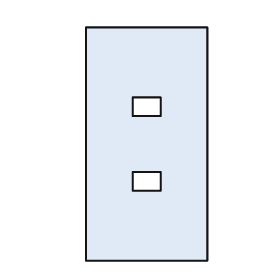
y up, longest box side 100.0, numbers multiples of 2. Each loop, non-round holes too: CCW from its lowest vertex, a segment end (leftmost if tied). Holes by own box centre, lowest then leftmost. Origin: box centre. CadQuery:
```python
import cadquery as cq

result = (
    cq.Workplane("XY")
    .moveTo(-26.0, -50.0)
    .lineTo(26.0, -50.0)
    .lineTo(26.0, 50.0)
    .lineTo(-26.0, 50.0)
    .close()
    .moveTo(-6.0, -20.0)
    .lineTo(6.0, -20.0)
    .lineTo(6.0, -12.0)
    .lineTo(-6.0, -12.0)
    .close()
    .moveTo(-6.0, 12.0)
    .lineTo(6.0, 12.0)
    .lineTo(6.0, 20.0)
    .lineTo(-6.0, 20.0)
    .close()
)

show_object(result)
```